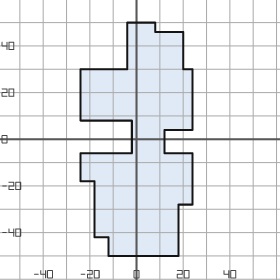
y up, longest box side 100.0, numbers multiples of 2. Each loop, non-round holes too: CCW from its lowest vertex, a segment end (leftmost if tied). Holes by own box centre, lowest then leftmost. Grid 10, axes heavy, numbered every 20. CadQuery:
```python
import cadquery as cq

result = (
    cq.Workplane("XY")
    .moveTo(-12.0, -50.0)
    .lineTo(18.0, -50.0)
    .lineTo(18.0, -28.0)
    .lineTo(24.0, -28.0)
    .lineTo(24.0, -6.0)
    .lineTo(12.0, -6.0)
    .lineTo(12.0, 4.0)
    .lineTo(24.0, 4.0)
    .lineTo(24.0, 30.0)
    .lineTo(20.0, 30.0)
    .lineTo(20.0, 46.0)
    .lineTo(8.0, 46.0)
    .lineTo(8.0, 50.0)
    .lineTo(-4.0, 50.0)
    .lineTo(-4.0, 30.0)
    .lineTo(-24.0, 30.0)
    .lineTo(-24.0, 8.0)
    .lineTo(-2.0, 8.0)
    .lineTo(-2.0, -6.0)
    .lineTo(-24.0, -6.0)
    .lineTo(-24.0, -18.0)
    .lineTo(-18.0, -18.0)
    .lineTo(-18.0, -42.0)
    .lineTo(-12.0, -42.0)
    .close()
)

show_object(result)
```